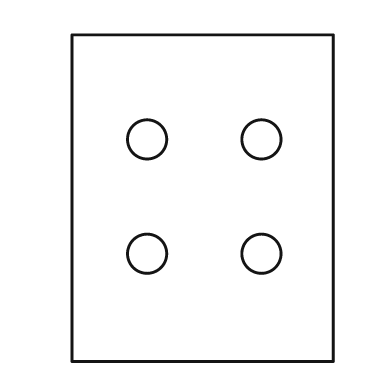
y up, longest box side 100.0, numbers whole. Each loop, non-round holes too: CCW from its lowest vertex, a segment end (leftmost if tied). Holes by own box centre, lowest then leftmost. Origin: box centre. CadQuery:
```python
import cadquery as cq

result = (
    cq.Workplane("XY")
    .moveTo(-40.0, -50.0)
    .lineTo(40.0, -50.0)
    .lineTo(40.0, 50.0)
    .lineTo(-40.0, 50.0)
    .close()
    .moveTo(-17.0, -17.0)
    .circle(6.0)
    .moveTo(18.0, -17.0)
    .circle(6.0)
    .moveTo(-17.0, 18.0)
    .circle(6.0)
    .moveTo(18.0, 18.0)
    .circle(6.0)
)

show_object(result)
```